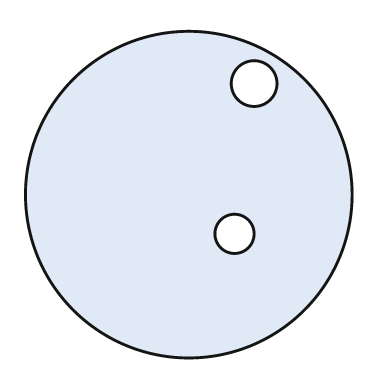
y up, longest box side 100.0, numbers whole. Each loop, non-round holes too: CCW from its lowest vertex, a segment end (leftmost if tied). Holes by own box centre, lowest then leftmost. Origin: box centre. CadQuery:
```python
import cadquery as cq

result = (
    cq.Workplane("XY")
    .moveTo(0.0, 0.0)
    .circle(50.0)
    .moveTo(14.0, -12.0)
    .circle(6.0)
    .moveTo(20.0, 34.0)
    .circle(7.0)
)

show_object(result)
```